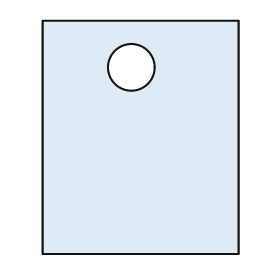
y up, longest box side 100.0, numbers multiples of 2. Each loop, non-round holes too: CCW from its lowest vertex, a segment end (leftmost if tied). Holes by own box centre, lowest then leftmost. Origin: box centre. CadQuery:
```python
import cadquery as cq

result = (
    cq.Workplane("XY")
    .moveTo(-42.0, -50.0)
    .lineTo(42.0, -50.0)
    .lineTo(42.0, 50.0)
    .lineTo(-42.0, 50.0)
    .close()
    .moveTo(-4.0, 30.0)
    .circle(10.0)
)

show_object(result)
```